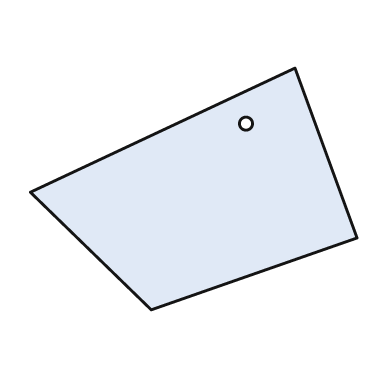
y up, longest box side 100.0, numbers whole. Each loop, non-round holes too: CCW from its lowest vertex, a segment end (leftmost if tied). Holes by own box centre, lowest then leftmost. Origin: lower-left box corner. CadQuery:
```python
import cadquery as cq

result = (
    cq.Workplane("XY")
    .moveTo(37.0, 0.0)
    .lineTo(100.0, 22.0)
    .lineTo(81.0, 74.0)
    .lineTo(0.0, 36.0)
    .close()
    .moveTo(66.0, 57.0)
    .circle(2.0)
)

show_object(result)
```